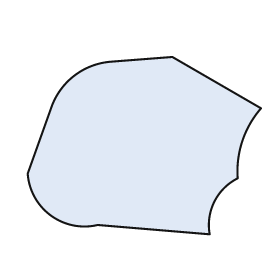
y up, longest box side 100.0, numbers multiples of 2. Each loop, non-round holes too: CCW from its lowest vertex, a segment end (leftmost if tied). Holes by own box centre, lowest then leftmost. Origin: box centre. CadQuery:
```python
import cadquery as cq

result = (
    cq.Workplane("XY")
    .moveTo(28.0, -38.0)
    .threePointArc((30.0, -24.0), (40.0, -14.0))
    .threePointArc((42.0, 2.0), (50.0, 16.0))
    .lineTo(12.0, 38.0)
    .lineTo(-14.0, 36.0)
    .threePointArc((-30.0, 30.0), (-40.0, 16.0))
    .lineTo(-50.0, -12.0)
    .threePointArc((-40.0, -30.0), (-20.0, -34.0))
    .close()
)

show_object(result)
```